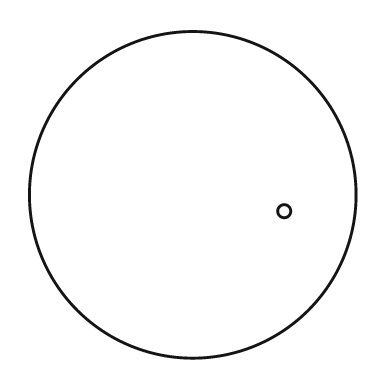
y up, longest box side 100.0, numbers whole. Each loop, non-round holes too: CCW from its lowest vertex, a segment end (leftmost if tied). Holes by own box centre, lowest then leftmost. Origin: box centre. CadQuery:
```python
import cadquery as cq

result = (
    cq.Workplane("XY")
    .moveTo(0.0, 0.0)
    .circle(50.0)
    .moveTo(28.0, -5.0)
    .circle(2.0)
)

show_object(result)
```